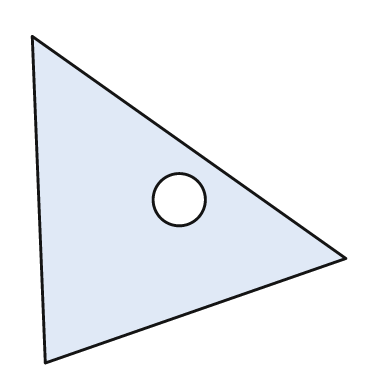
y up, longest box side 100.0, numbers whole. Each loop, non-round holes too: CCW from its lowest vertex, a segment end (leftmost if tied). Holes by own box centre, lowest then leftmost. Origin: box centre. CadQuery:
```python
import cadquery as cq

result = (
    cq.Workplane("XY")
    .moveTo(-44.0, -50.0)
    .lineTo(48.0, -18.0)
    .lineTo(-48.0, 50.0)
    .close()
    .moveTo(-3.0, 0.0)
    .circle(8.0)
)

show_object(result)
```